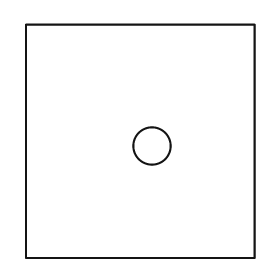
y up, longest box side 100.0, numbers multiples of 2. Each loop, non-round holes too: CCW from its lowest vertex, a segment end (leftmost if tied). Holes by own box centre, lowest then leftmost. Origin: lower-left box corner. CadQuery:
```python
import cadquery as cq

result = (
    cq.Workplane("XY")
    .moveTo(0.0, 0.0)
    .lineTo(98.0, 0.0)
    .lineTo(98.0, 100.0)
    .lineTo(0.0, 100.0)
    .close()
    .moveTo(54.0, 48.0)
    .circle(8.0)
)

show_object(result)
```